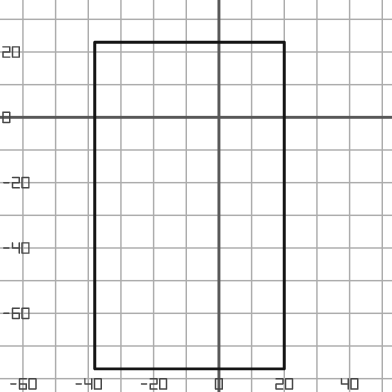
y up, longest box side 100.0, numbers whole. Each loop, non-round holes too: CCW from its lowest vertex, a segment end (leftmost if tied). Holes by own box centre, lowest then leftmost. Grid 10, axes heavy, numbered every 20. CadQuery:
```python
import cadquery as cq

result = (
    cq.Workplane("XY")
    .moveTo(-38.0, -77.0)
    .lineTo(20.0, -77.0)
    .lineTo(20.0, 23.0)
    .lineTo(-38.0, 23.0)
    .close()
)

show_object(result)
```